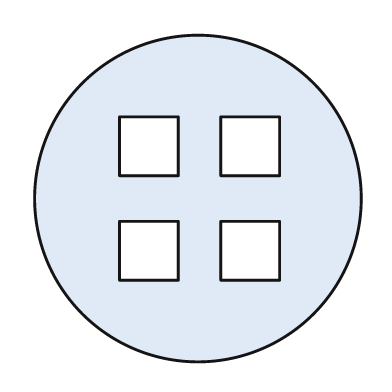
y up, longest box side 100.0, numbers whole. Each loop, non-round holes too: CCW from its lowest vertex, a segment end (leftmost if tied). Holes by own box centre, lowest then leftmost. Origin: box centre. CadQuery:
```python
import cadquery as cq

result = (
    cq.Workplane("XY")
    .moveTo(0.0, 0.0)
    .circle(50.0)
    .moveTo(-24.0, -25.0)
    .lineTo(-6.0, -25.0)
    .lineTo(-6.0, -7.0)
    .lineTo(-24.0, -7.0)
    .close()
    .moveTo(7.0, -25.0)
    .lineTo(25.0, -25.0)
    .lineTo(25.0, -7.0)
    .lineTo(7.0, -7.0)
    .close()
    .moveTo(-24.0, 7.0)
    .lineTo(-6.0, 7.0)
    .lineTo(-6.0, 25.0)
    .lineTo(-24.0, 25.0)
    .close()
    .moveTo(7.0, 7.0)
    .lineTo(25.0, 7.0)
    .lineTo(25.0, 25.0)
    .lineTo(7.0, 25.0)
    .close()
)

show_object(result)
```